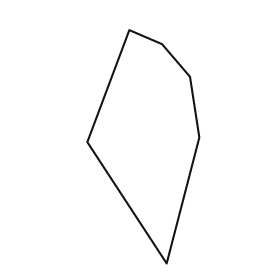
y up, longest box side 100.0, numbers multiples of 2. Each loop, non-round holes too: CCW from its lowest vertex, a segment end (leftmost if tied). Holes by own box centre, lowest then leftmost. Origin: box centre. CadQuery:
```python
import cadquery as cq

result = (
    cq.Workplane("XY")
    .moveTo(10.0, -50.0)
    .lineTo(24.0, 4.0)
    .lineTo(20.0, 30.0)
    .lineTo(8.0, 44.0)
    .lineTo(-6.0, 50.0)
    .lineTo(-24.0, 2.0)
    .close()
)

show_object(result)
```